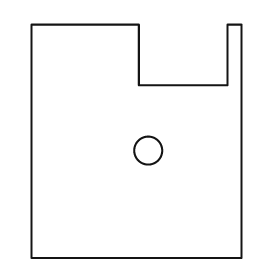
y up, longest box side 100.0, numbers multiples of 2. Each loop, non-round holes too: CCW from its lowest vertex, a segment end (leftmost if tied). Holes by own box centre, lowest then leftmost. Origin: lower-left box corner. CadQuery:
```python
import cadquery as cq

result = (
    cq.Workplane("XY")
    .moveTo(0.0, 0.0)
    .lineTo(90.0, 0.0)
    .lineTo(90.0, 100.0)
    .lineTo(84.0, 100.0)
    .lineTo(84.0, 74.0)
    .lineTo(46.0, 74.0)
    .lineTo(46.0, 100.0)
    .lineTo(0.0, 100.0)
    .close()
    .moveTo(50.0, 46.0)
    .circle(6.0)
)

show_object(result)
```